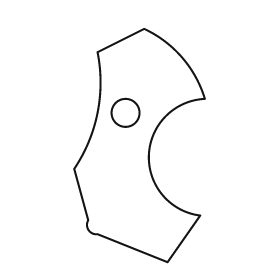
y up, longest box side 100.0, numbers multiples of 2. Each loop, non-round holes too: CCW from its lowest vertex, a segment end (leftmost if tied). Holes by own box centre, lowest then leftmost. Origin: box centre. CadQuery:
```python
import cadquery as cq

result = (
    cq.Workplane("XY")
    .moveTo(12.0, -50.0)
    .lineTo(26.0, -30.0)
    .threePointArc((4.0, -4.0), (28.0, 20.0))
    .threePointArc((18.0, 38.0), (2.0, 50.0))
    .lineTo(-18.0, 40.0)
    .threePointArc((-18.0, 14.0), (-28.0, -10.0))
    .lineTo(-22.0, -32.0)
    .threePointArc((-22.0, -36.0), (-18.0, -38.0))
    .close()
    .moveTo(-6.0, 14.0)
    .circle(6.0)
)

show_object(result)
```